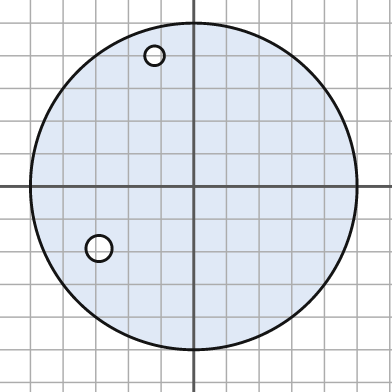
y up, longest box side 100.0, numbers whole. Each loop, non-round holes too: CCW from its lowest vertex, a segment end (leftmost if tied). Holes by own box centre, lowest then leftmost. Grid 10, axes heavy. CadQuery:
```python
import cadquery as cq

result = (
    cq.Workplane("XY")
    .moveTo(0.0, 0.0)
    .circle(50.0)
    .moveTo(-29.0, -19.0)
    .circle(4.0)
    .moveTo(-12.0, 40.0)
    .circle(3.0)
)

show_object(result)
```